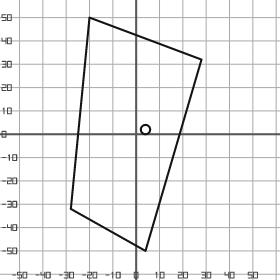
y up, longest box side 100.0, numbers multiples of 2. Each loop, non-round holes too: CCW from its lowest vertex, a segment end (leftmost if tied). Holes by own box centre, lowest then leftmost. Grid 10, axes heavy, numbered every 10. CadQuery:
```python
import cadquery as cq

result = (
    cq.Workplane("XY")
    .moveTo(4.0, -50.0)
    .lineTo(28.0, 32.0)
    .lineTo(-20.0, 50.0)
    .lineTo(-28.0, -32.0)
    .close()
    .moveTo(4.0, 2.0)
    .circle(2.0)
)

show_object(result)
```